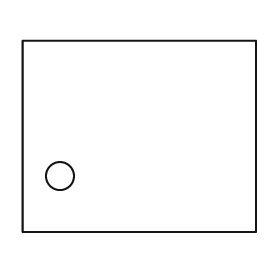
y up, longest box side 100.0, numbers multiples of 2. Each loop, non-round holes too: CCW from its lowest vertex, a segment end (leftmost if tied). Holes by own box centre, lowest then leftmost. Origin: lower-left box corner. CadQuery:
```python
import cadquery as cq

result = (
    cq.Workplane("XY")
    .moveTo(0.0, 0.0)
    .lineTo(100.0, 0.0)
    .lineTo(100.0, 82.0)
    .lineTo(0.0, 82.0)
    .close()
    .moveTo(16.0, 24.0)
    .circle(6.0)
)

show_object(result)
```